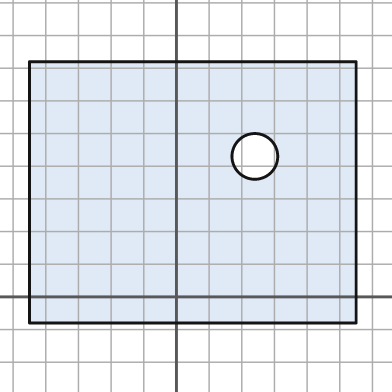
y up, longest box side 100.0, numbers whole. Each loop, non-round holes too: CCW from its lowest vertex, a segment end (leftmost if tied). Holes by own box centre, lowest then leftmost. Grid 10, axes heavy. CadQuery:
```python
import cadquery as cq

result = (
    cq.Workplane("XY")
    .moveTo(-45.0, -8.0)
    .lineTo(55.0, -8.0)
    .lineTo(55.0, 72.0)
    .lineTo(-45.0, 72.0)
    .close()
    .moveTo(24.0, 43.0)
    .circle(7.0)
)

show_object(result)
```